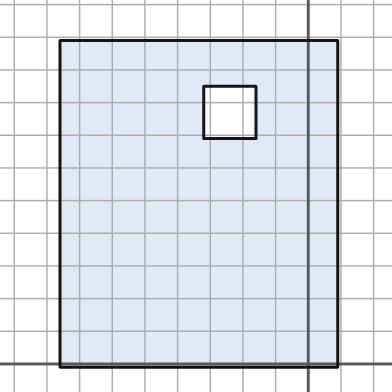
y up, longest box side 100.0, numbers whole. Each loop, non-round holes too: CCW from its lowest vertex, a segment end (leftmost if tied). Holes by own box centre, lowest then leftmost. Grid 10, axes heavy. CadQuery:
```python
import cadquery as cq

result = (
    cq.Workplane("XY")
    .moveTo(-76.0, -1.0)
    .lineTo(9.0, -1.0)
    .lineTo(9.0, 99.0)
    .lineTo(-76.0, 99.0)
    .close()
    .moveTo(-32.0, 69.0)
    .lineTo(-16.0, 69.0)
    .lineTo(-16.0, 85.0)
    .lineTo(-32.0, 85.0)
    .close()
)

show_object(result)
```